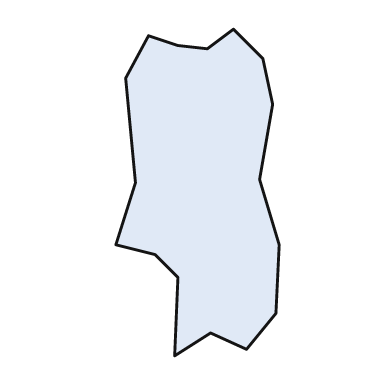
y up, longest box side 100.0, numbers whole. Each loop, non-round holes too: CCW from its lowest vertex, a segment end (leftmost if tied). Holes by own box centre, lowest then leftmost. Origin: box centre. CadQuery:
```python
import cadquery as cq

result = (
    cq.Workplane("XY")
    .moveTo(-7.0, -50.0)
    .lineTo(4.0, -43.0)
    .lineTo(15.0, -48.0)
    .lineTo(24.0, -37.0)
    .lineTo(25.0, -16.0)
    .lineTo(19.0, 4.0)
    .lineTo(23.0, 27.0)
    .lineTo(20.0, 41.0)
    .lineTo(11.0, 50.0)
    .lineTo(3.0, 44.0)
    .lineTo(-6.0, 45.0)
    .lineTo(-15.0, 48.0)
    .lineTo(-22.0, 35.0)
    .lineTo(-19.0, 3.0)
    .lineTo(-25.0, -16.0)
    .lineTo(-13.0, -19.0)
    .lineTo(-6.0, -26.0)
    .close()
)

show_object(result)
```